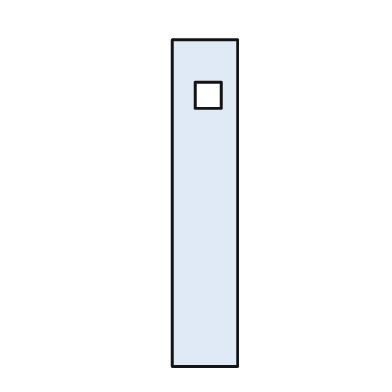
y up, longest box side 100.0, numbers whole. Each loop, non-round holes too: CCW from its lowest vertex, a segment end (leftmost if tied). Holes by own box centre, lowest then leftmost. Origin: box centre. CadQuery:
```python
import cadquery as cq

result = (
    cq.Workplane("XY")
    .moveTo(-10.0, -50.0)
    .lineTo(10.0, -50.0)
    .lineTo(10.0, 50.0)
    .lineTo(-10.0, 50.0)
    .close()
    .moveTo(-3.0, 29.0)
    .lineTo(5.0, 29.0)
    .lineTo(5.0, 37.0)
    .lineTo(-3.0, 37.0)
    .close()
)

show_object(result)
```